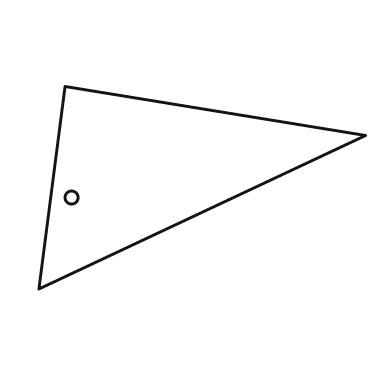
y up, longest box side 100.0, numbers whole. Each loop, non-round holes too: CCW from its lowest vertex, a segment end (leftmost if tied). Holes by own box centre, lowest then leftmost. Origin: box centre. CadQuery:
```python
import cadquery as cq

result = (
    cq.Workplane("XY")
    .moveTo(-50.0, -31.0)
    .lineTo(50.0, 16.0)
    .lineTo(-42.0, 31.0)
    .close()
    .moveTo(-40.0, -3.0)
    .circle(2.0)
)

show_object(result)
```